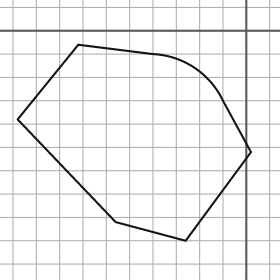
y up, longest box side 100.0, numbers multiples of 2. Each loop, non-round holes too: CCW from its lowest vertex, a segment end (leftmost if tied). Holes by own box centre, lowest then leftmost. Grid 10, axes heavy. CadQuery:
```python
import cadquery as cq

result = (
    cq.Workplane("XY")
    .moveTo(-26.0, -90.0)
    .lineTo(2.0, -52.0)
    .lineTo(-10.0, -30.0)
    .threePointArc((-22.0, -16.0), (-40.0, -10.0))
    .lineTo(-72.0, -6.0)
    .lineTo(-98.0, -38.0)
    .lineTo(-56.0, -82.0)
    .close()
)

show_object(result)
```